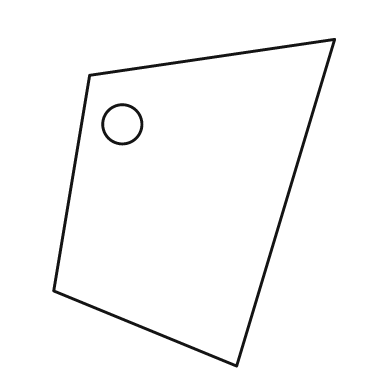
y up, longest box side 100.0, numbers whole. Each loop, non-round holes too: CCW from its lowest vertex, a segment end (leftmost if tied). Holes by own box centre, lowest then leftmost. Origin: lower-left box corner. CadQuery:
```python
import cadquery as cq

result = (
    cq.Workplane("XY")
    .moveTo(56.0, 0.0)
    .lineTo(86.0, 100.0)
    .lineTo(11.0, 89.0)
    .lineTo(0.0, 23.0)
    .close()
    .moveTo(21.0, 74.0)
    .circle(6.0)
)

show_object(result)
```